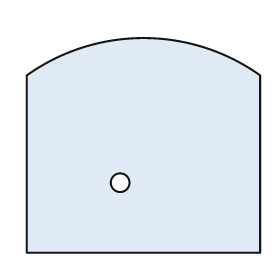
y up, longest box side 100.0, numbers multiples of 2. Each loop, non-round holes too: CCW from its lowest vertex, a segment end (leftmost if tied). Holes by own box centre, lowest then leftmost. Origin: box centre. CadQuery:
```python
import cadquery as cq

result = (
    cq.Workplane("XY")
    .moveTo(-50.0, -46.0)
    .lineTo(50.0, -46.0)
    .lineTo(50.0, 30.0)
    .threePointArc((0.0, 46.0), (-50.0, 30.0))
    .close()
    .moveTo(-10.0, -16.0)
    .circle(4.0)
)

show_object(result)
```